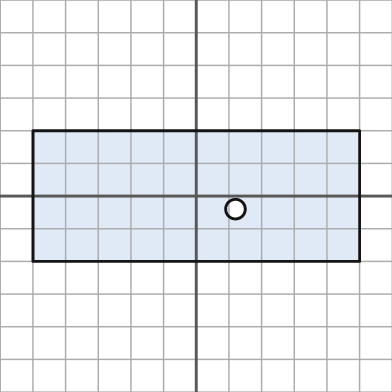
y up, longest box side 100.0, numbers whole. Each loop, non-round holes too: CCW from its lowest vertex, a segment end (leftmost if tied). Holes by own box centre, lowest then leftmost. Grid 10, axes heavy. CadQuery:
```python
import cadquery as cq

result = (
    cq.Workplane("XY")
    .moveTo(-50.0, -20.0)
    .lineTo(50.0, -20.0)
    .lineTo(50.0, 20.0)
    .lineTo(-50.0, 20.0)
    .close()
    .moveTo(12.0, -4.0)
    .circle(3.0)
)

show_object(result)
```